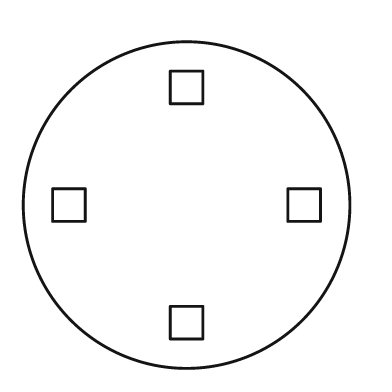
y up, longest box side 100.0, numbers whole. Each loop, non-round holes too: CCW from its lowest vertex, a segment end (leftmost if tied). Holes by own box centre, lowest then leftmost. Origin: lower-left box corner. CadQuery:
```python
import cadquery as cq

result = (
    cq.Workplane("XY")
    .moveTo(50.0, 50.0)
    .circle(50.0)
    .moveTo(45.0, 9.0)
    .lineTo(55.0, 9.0)
    .lineTo(55.0, 19.0)
    .lineTo(45.0, 19.0)
    .close()
    .moveTo(9.0, 45.0)
    .lineTo(19.0, 45.0)
    .lineTo(19.0, 55.0)
    .lineTo(9.0, 55.0)
    .close()
    .moveTo(81.0, 45.0)
    .lineTo(91.0, 45.0)
    .lineTo(91.0, 55.0)
    .lineTo(81.0, 55.0)
    .close()
    .moveTo(45.0, 81.0)
    .lineTo(55.0, 81.0)
    .lineTo(55.0, 91.0)
    .lineTo(45.0, 91.0)
    .close()
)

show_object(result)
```